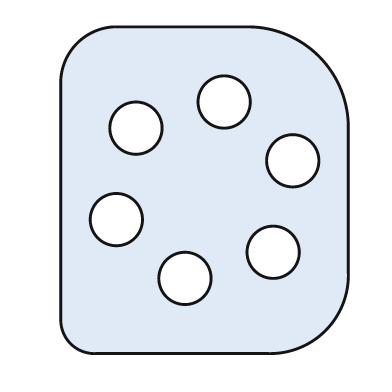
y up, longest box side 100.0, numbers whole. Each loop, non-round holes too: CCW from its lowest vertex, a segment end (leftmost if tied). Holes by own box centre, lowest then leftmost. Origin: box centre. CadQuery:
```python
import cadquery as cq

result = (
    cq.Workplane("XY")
    .moveTo(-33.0, -50.0)
    .lineTo(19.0, -50.0)
    .threePointArc((37.0, -43.0), (44.0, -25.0))
    .lineTo(44.0, 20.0)
    .threePointArc((35.0, 41.0), (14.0, 50.0))
    .lineTo(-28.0, 50.0)
    .threePointArc((-39.0, 45.0), (-44.0, 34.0))
    .lineTo(-44.0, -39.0)
    .threePointArc((-41.0, -47.0), (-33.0, -50.0))
    .close()
    .moveTo(-6.0, -27.0)
    .circle(8.0)
    .moveTo(21.0, -19.0)
    .circle(8.0)
    .moveTo(-27.0, -9.0)
    .circle(8.0)
    .moveTo(27.0, 9.0)
    .circle(8.0)
    .moveTo(-21.0, 19.0)
    .circle(8.0)
    .moveTo(6.0, 27.0)
    .circle(8.0)
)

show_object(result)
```